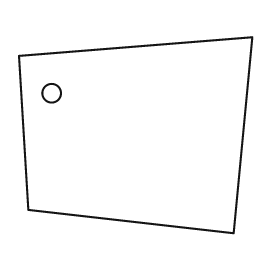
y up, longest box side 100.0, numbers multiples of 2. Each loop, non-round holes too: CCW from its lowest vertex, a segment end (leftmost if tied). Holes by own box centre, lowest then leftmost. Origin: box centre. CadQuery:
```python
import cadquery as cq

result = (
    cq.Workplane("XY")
    .moveTo(42.0, -42.0)
    .lineTo(50.0, 42.0)
    .lineTo(-50.0, 34.0)
    .lineTo(-46.0, -32.0)
    .close()
    .moveTo(-36.0, 18.0)
    .circle(4.0)
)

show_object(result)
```